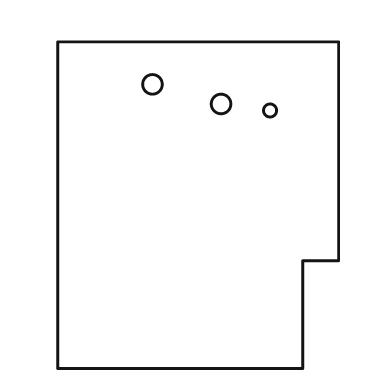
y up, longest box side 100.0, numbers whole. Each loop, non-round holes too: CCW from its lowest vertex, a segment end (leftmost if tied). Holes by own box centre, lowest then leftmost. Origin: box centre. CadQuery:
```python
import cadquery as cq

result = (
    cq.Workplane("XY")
    .moveTo(-43.0, -50.0)
    .lineTo(32.0, -50.0)
    .lineTo(32.0, -17.0)
    .lineTo(43.0, -17.0)
    .lineTo(43.0, 50.0)
    .lineTo(-43.0, 50.0)
    .close()
    .moveTo(22.0, 29.0)
    .circle(2.0)
    .moveTo(7.0, 31.0)
    .circle(3.0)
    .moveTo(-14.0, 37.0)
    .circle(3.0)
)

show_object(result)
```